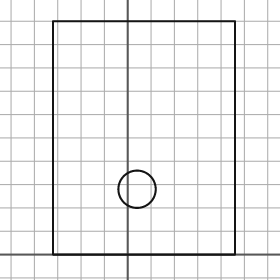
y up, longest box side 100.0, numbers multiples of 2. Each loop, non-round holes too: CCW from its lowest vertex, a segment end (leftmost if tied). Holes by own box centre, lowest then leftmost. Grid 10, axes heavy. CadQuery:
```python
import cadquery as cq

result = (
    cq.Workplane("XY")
    .moveTo(-32.0, 0.0)
    .lineTo(46.0, 0.0)
    .lineTo(46.0, 100.0)
    .lineTo(-32.0, 100.0)
    .close()
    .moveTo(4.0, 28.0)
    .circle(8.0)
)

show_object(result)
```